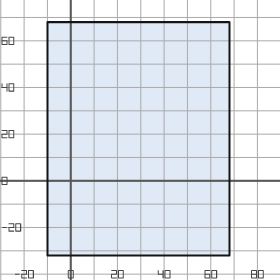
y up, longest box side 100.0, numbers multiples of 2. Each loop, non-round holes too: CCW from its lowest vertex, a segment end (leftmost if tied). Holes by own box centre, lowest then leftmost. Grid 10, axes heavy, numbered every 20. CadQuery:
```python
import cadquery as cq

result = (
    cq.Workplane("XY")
    .moveTo(-10.0, -32.0)
    .lineTo(68.0, -32.0)
    .lineTo(68.0, 68.0)
    .lineTo(-10.0, 68.0)
    .close()
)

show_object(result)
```